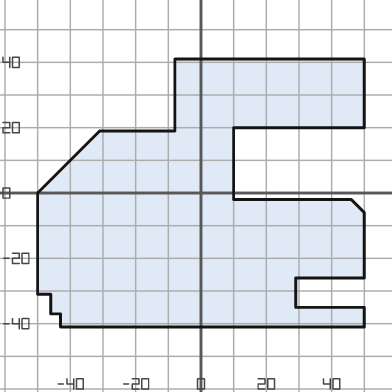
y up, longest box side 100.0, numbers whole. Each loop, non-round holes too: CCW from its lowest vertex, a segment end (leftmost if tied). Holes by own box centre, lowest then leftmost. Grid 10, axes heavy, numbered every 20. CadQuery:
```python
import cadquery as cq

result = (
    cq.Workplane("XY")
    .moveTo(-43.0, -41.0)
    .lineTo(50.0, -41.0)
    .lineTo(50.0, -35.0)
    .lineTo(29.0, -35.0)
    .lineTo(29.0, -26.0)
    .lineTo(50.0, -26.0)
    .lineTo(50.0, -6.0)
    .lineTo(46.0, -2.0)
    .lineTo(10.0, -2.0)
    .lineTo(10.0, 20.0)
    .lineTo(50.0, 20.0)
    .lineTo(50.0, 41.0)
    .lineTo(-8.0, 41.0)
    .lineTo(-8.0, 19.0)
    .lineTo(-31.0, 19.0)
    .lineTo(-50.0, 0.0)
    .lineTo(-50.0, -31.0)
    .lineTo(-46.0, -31.0)
    .lineTo(-46.0, -37.0)
    .lineTo(-43.0, -37.0)
    .close()
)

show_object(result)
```